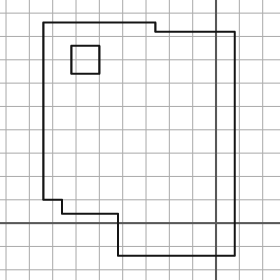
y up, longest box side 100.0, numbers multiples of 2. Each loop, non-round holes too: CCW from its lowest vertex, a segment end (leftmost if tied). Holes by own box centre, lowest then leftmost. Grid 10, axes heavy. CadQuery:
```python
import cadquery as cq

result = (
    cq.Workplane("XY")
    .moveTo(-42.0, -14.0)
    .lineTo(8.0, -14.0)
    .lineTo(8.0, 82.0)
    .lineTo(-26.0, 82.0)
    .lineTo(-26.0, 86.0)
    .lineTo(-74.0, 86.0)
    .lineTo(-74.0, 10.0)
    .lineTo(-66.0, 10.0)
    .lineTo(-66.0, 4.0)
    .lineTo(-42.0, 4.0)
    .close()
    .moveTo(-62.0, 64.0)
    .lineTo(-50.0, 64.0)
    .lineTo(-50.0, 76.0)
    .lineTo(-62.0, 76.0)
    .close()
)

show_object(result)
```